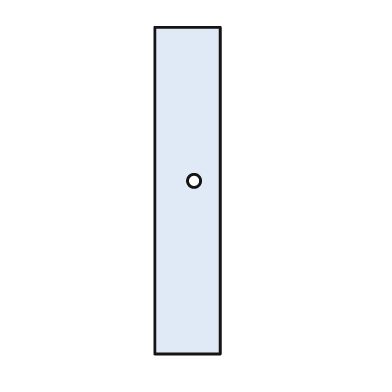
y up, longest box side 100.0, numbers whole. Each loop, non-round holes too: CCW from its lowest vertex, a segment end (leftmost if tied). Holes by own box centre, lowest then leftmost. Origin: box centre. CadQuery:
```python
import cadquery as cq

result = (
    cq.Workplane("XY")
    .moveTo(-10.0, -50.0)
    .lineTo(10.0, -50.0)
    .lineTo(10.0, 50.0)
    .lineTo(-10.0, 50.0)
    .close()
    .moveTo(2.0, 3.0)
    .circle(2.0)
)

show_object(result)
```